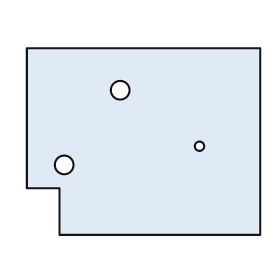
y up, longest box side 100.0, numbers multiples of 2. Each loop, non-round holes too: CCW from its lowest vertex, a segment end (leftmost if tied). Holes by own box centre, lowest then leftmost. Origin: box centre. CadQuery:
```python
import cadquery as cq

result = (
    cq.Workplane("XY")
    .moveTo(-36.0, -40.0)
    .lineTo(50.0, -40.0)
    .lineTo(50.0, 40.0)
    .lineTo(-50.0, 40.0)
    .lineTo(-50.0, -20.0)
    .lineTo(-36.0, -20.0)
    .close()
    .moveTo(-34.0, -10.0)
    .circle(4.0)
    .moveTo(24.0, -2.0)
    .circle(2.0)
    .moveTo(-10.0, 22.0)
    .circle(4.0)
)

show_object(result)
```